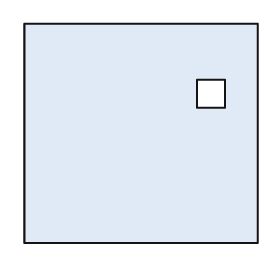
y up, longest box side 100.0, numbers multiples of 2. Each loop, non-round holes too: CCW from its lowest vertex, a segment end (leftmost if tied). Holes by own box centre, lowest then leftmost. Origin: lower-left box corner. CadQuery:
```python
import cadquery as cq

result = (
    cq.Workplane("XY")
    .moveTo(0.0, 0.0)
    .lineTo(100.0, 0.0)
    .lineTo(100.0, 94.0)
    .lineTo(0.0, 94.0)
    .close()
    .moveTo(74.0, 58.0)
    .lineTo(86.0, 58.0)
    .lineTo(86.0, 70.0)
    .lineTo(74.0, 70.0)
    .close()
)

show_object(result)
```